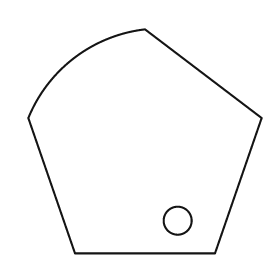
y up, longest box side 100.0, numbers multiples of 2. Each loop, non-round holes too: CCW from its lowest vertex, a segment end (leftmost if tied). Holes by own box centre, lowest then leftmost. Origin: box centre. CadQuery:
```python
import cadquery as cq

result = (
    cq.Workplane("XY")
    .moveTo(-30.0, -48.0)
    .lineTo(30.0, -48.0)
    .lineTo(50.0, 10.0)
    .lineTo(0.0, 48.0)
    .threePointArc((-30.0, 36.0), (-50.0, 10.0))
    .close()
    .moveTo(14.0, -34.0)
    .circle(6.0)
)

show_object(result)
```